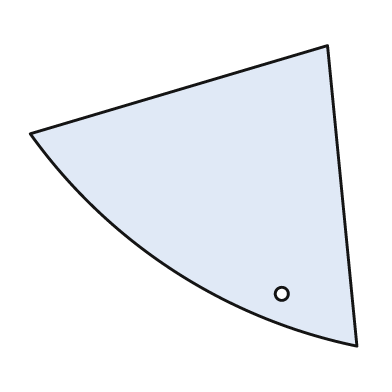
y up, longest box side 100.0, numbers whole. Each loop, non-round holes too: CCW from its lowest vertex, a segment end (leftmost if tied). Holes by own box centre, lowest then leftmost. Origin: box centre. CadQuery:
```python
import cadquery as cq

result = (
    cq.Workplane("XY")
    .moveTo(50.0, -46.0)
    .lineTo(41.0, 46.0)
    .lineTo(-50.0, 19.0)
    .threePointArc((-6.0, -23.0), (50.0, -46.0))
    .close()
    .moveTo(27.0, -30.0)
    .circle(2.0)
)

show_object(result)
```